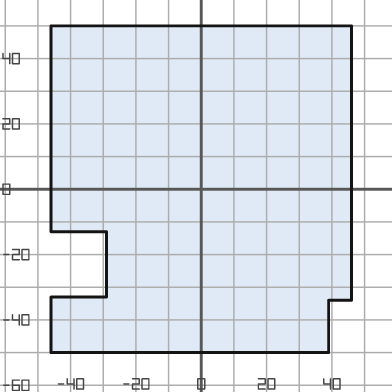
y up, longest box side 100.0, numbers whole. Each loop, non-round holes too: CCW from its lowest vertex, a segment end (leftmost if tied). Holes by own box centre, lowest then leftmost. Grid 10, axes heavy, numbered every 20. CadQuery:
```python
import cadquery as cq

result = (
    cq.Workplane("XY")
    .moveTo(-46.0, -50.0)
    .lineTo(39.0, -50.0)
    .lineTo(39.0, -34.0)
    .lineTo(46.0, -34.0)
    .lineTo(46.0, 50.0)
    .lineTo(-46.0, 50.0)
    .lineTo(-46.0, -13.0)
    .lineTo(-29.0, -13.0)
    .lineTo(-29.0, -33.0)
    .lineTo(-46.0, -33.0)
    .close()
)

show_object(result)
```